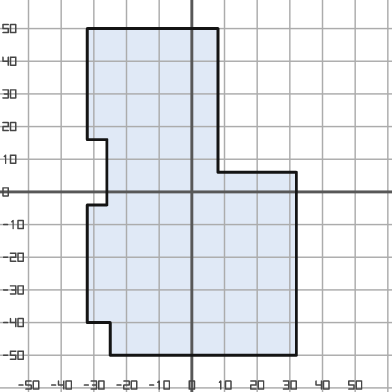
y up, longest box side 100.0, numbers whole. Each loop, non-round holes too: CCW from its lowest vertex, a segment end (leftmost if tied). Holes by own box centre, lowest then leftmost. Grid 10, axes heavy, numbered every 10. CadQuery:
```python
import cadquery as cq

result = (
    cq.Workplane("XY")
    .moveTo(-25.0, -50.0)
    .lineTo(32.0, -50.0)
    .lineTo(32.0, 6.0)
    .lineTo(8.0, 6.0)
    .lineTo(8.0, 50.0)
    .lineTo(-32.0, 50.0)
    .lineTo(-32.0, 16.0)
    .lineTo(-26.0, 16.0)
    .lineTo(-26.0, -4.0)
    .lineTo(-32.0, -4.0)
    .lineTo(-32.0, -40.0)
    .lineTo(-25.0, -40.0)
    .close()
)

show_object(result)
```